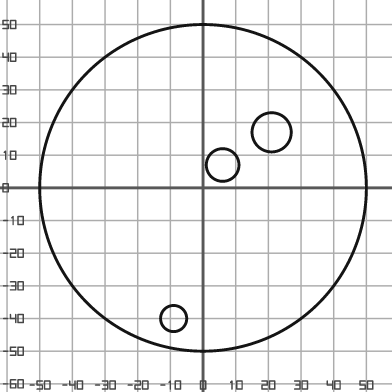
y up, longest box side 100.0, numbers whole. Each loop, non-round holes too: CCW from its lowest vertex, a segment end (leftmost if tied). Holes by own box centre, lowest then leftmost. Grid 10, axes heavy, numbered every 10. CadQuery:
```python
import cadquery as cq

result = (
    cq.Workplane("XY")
    .moveTo(0.0, 0.0)
    .circle(50.0)
    .moveTo(-9.0, -40.0)
    .circle(4.0)
    .moveTo(6.0, 7.0)
    .circle(5.0)
    .moveTo(21.0, 17.0)
    .circle(6.0)
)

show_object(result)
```